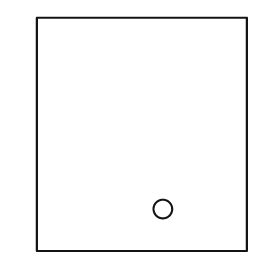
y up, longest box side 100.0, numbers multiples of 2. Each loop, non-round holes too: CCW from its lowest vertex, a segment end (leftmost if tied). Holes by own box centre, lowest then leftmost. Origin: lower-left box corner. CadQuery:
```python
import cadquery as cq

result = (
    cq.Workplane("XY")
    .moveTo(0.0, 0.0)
    .lineTo(90.0, 0.0)
    .lineTo(90.0, 100.0)
    .lineTo(0.0, 100.0)
    .close()
    .moveTo(54.0, 18.0)
    .circle(4.0)
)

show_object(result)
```